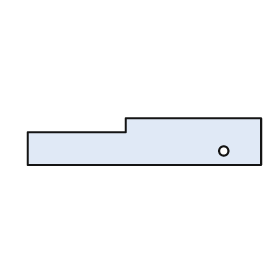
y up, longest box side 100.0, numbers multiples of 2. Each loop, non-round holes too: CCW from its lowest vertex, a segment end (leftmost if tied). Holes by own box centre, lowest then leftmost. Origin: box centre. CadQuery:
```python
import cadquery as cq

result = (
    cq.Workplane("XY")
    .moveTo(-50.0, -10.0)
    .lineTo(50.0, -10.0)
    .lineTo(50.0, 10.0)
    .lineTo(-8.0, 10.0)
    .lineTo(-8.0, 4.0)
    .lineTo(-50.0, 4.0)
    .close()
    .moveTo(34.0, -4.0)
    .circle(2.0)
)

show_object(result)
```